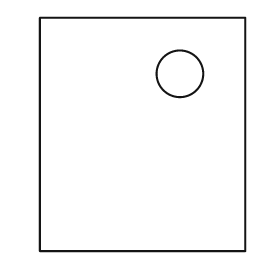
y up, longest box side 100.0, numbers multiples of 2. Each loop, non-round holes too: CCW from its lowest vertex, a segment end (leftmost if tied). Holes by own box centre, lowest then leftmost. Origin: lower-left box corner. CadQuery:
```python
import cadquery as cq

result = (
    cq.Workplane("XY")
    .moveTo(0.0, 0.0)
    .lineTo(88.0, 0.0)
    .lineTo(88.0, 100.0)
    .lineTo(0.0, 100.0)
    .close()
    .moveTo(60.0, 76.0)
    .circle(10.0)
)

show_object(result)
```